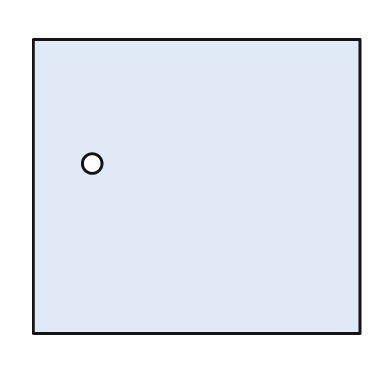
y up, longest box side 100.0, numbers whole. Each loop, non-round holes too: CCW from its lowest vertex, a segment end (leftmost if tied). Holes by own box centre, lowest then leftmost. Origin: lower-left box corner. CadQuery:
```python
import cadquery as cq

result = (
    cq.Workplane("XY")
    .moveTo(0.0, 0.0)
    .lineTo(100.0, 0.0)
    .lineTo(100.0, 90.0)
    .lineTo(0.0, 90.0)
    .close()
    .moveTo(18.0, 52.0)
    .circle(3.0)
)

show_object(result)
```